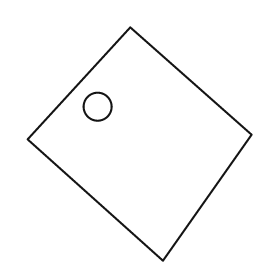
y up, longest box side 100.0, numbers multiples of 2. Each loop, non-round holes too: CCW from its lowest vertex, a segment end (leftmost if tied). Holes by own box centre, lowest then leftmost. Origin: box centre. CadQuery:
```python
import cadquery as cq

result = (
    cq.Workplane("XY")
    .moveTo(10.0, -50.0)
    .lineTo(48.0, 4.0)
    .lineTo(-4.0, 50.0)
    .lineTo(-48.0, 2.0)
    .close()
    .moveTo(-18.0, 16.0)
    .circle(6.0)
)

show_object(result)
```